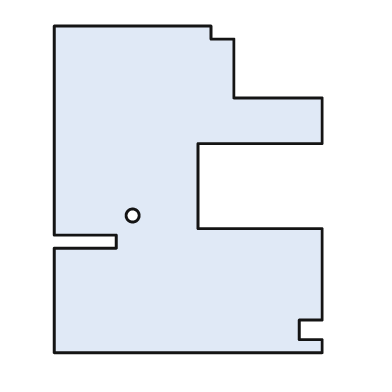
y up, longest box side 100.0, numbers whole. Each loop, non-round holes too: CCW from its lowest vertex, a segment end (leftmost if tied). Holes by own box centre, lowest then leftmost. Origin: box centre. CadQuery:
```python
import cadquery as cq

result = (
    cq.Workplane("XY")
    .moveTo(-41.0, -50.0)
    .lineTo(41.0, -50.0)
    .lineTo(41.0, -46.0)
    .lineTo(34.0, -46.0)
    .lineTo(34.0, -40.0)
    .lineTo(41.0, -40.0)
    .lineTo(41.0, -12.0)
    .lineTo(3.0, -12.0)
    .lineTo(3.0, 14.0)
    .lineTo(41.0, 14.0)
    .lineTo(41.0, 28.0)
    .lineTo(14.0, 28.0)
    .lineTo(14.0, 46.0)
    .lineTo(7.0, 46.0)
    .lineTo(7.0, 50.0)
    .lineTo(-41.0, 50.0)
    .lineTo(-41.0, -14.0)
    .lineTo(-22.0, -14.0)
    .lineTo(-22.0, -18.0)
    .lineTo(-41.0, -18.0)
    .close()
    .moveTo(-17.0, -8.0)
    .circle(2.0)
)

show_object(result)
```